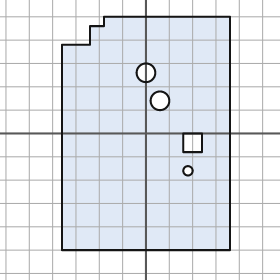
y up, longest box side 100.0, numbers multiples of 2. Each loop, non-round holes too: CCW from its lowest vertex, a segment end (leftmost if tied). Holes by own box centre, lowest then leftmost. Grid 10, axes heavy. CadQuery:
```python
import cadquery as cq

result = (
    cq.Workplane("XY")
    .moveTo(-36.0, -50.0)
    .lineTo(36.0, -50.0)
    .lineTo(36.0, 50.0)
    .lineTo(-18.0, 50.0)
    .lineTo(-18.0, 46.0)
    .lineTo(-24.0, 46.0)
    .lineTo(-24.0, 38.0)
    .lineTo(-36.0, 38.0)
    .close()
    .moveTo(18.0, -16.0)
    .circle(2.0)
    .moveTo(16.0, -8.0)
    .lineTo(24.0, -8.0)
    .lineTo(24.0, 0.0)
    .lineTo(16.0, 0.0)
    .close()
    .moveTo(6.0, 14.0)
    .circle(4.0)
    .moveTo(0.0, 26.0)
    .circle(4.0)
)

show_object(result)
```